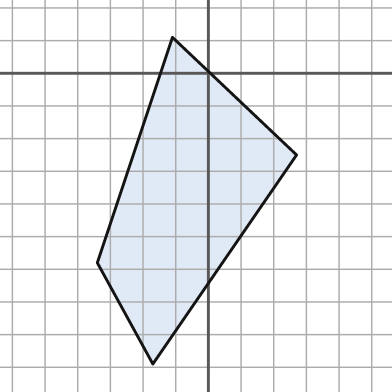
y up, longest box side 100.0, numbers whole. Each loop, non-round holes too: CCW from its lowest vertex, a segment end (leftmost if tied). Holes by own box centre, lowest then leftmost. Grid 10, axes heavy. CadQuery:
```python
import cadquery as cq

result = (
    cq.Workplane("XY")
    .moveTo(-17.0, -89.0)
    .lineTo(27.0, -25.0)
    .lineTo(-11.0, 11.0)
    .lineTo(-34.0, -58.0)
    .close()
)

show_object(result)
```